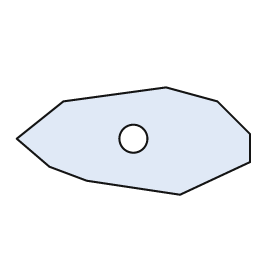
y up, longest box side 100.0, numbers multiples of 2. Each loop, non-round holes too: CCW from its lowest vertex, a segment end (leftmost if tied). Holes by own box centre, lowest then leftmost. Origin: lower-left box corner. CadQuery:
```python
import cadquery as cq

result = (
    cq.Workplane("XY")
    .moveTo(70.0, 0.0)
    .lineTo(100.0, 14.0)
    .lineTo(100.0, 26.0)
    .lineTo(86.0, 40.0)
    .lineTo(64.0, 46.0)
    .lineTo(20.0, 40.0)
    .lineTo(0.0, 24.0)
    .lineTo(14.0, 12.0)
    .lineTo(30.0, 6.0)
    .close()
    .moveTo(50.0, 24.0)
    .circle(6.0)
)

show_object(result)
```